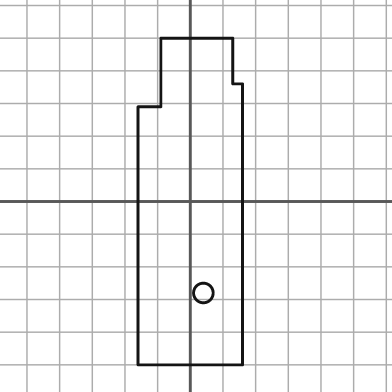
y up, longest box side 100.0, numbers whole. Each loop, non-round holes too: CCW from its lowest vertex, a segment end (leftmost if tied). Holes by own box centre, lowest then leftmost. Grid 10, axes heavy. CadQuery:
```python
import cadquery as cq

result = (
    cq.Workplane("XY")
    .moveTo(-16.0, -50.0)
    .lineTo(16.0, -50.0)
    .lineTo(16.0, 36.0)
    .lineTo(13.0, 36.0)
    .lineTo(13.0, 50.0)
    .lineTo(-9.0, 50.0)
    .lineTo(-9.0, 29.0)
    .lineTo(-16.0, 29.0)
    .close()
    .moveTo(4.0, -28.0)
    .circle(3.0)
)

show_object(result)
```